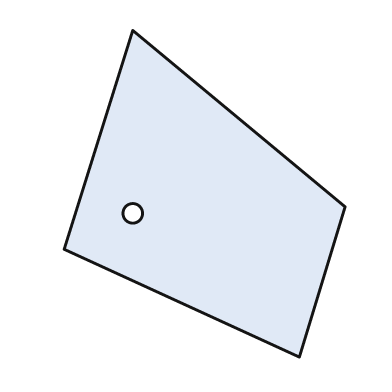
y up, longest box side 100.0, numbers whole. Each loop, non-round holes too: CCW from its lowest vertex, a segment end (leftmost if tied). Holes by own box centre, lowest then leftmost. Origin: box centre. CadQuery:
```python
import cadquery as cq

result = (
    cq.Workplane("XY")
    .moveTo(29.0, -50.0)
    .lineTo(43.0, -4.0)
    .lineTo(-22.0, 50.0)
    .lineTo(-43.0, -17.0)
    .close()
    .moveTo(-22.0, -6.0)
    .circle(3.0)
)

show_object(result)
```